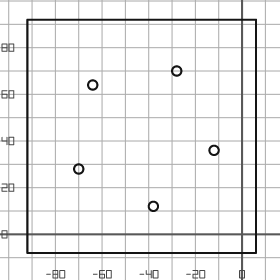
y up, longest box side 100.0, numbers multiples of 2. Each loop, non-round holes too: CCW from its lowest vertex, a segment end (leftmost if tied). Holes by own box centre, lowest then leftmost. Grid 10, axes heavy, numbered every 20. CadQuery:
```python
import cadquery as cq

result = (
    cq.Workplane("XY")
    .moveTo(-92.0, -8.0)
    .lineTo(6.0, -8.0)
    .lineTo(6.0, 92.0)
    .lineTo(-92.0, 92.0)
    .close()
    .moveTo(-38.0, 12.0)
    .circle(2.0)
    .moveTo(-70.0, 28.0)
    .circle(2.0)
    .moveTo(-12.0, 36.0)
    .circle(2.0)
    .moveTo(-64.0, 64.0)
    .circle(2.0)
    .moveTo(-28.0, 70.0)
    .circle(2.0)
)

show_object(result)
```